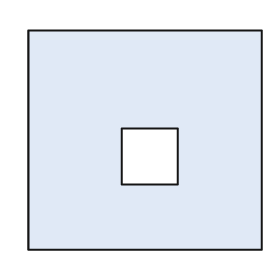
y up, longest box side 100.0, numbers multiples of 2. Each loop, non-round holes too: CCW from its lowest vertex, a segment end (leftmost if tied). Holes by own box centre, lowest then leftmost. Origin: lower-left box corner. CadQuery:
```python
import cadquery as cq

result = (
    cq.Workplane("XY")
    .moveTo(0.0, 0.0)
    .lineTo(100.0, 0.0)
    .lineTo(100.0, 94.0)
    .lineTo(0.0, 94.0)
    .close()
    .moveTo(40.0, 28.0)
    .lineTo(64.0, 28.0)
    .lineTo(64.0, 52.0)
    .lineTo(40.0, 52.0)
    .close()
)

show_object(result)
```